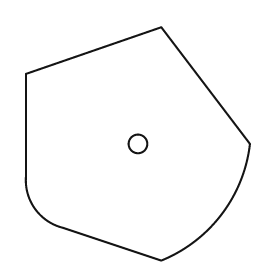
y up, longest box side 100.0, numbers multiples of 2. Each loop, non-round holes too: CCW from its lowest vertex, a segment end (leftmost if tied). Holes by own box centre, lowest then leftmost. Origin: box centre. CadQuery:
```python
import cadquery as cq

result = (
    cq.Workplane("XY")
    .moveTo(10.0, -50.0)
    .threePointArc((36.0, -30.0), (48.0, 0.0))
    .lineTo(10.0, 50.0)
    .lineTo(-48.0, 30.0)
    .lineTo(-48.0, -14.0)
    .threePointArc((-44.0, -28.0), (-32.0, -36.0))
    .close()
    .moveTo(0.0, 0.0)
    .circle(4.0)
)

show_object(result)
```